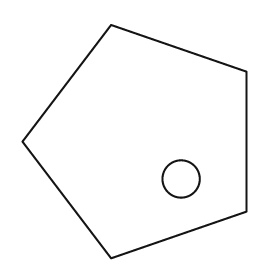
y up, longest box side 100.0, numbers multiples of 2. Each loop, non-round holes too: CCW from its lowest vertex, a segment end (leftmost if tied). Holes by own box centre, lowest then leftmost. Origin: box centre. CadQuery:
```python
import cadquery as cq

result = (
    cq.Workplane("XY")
    .moveTo(-10.0, -50.0)
    .lineTo(48.0, -30.0)
    .lineTo(48.0, 30.0)
    .lineTo(-10.0, 50.0)
    .lineTo(-48.0, 0.0)
    .close()
    .moveTo(20.0, -16.0)
    .circle(8.0)
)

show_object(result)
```